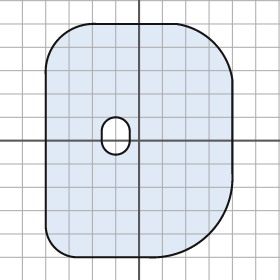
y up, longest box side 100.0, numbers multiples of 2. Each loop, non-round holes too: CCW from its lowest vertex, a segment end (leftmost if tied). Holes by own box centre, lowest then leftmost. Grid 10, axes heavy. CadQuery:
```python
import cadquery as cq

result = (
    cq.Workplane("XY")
    .moveTo(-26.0, -50.0)
    .lineTo(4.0, -50.0)
    .threePointArc((30.0, -40.0), (40.0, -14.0))
    .lineTo(40.0, 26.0)
    .threePointArc((32.0, 42.0), (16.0, 50.0))
    .lineTo(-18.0, 50.0)
    .threePointArc((-34.0, 44.0), (-40.0, 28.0))
    .lineTo(-40.0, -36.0)
    .threePointArc((-36.0, -46.0), (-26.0, -50.0))
    .close()
    .moveTo(-16.0, 0.0)
    .threePointArc((-10.0, -6.0), (-4.0, 0.0))
    .lineTo(-4.0, 4.0)
    .threePointArc((-10.0, 10.0), (-16.0, 4.0))
    .close()
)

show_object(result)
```